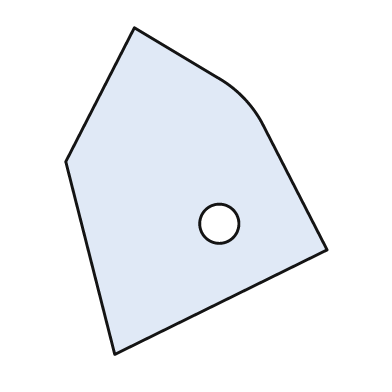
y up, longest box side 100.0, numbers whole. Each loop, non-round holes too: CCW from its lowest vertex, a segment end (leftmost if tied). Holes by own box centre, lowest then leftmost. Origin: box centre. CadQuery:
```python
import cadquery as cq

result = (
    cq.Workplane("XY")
    .moveTo(-25.0, -50.0)
    .lineTo(40.0, -18.0)
    .lineTo(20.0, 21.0)
    .threePointArc((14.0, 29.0), (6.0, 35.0))
    .lineTo(-19.0, 50.0)
    .lineTo(-40.0, 9.0)
    .close()
    .moveTo(7.0, -10.0)
    .circle(6.0)
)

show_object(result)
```